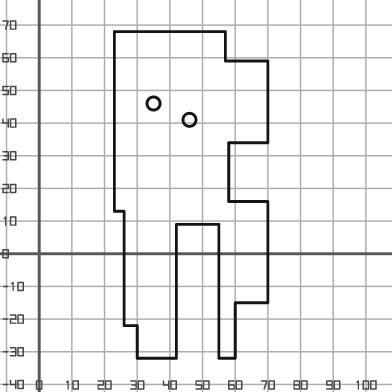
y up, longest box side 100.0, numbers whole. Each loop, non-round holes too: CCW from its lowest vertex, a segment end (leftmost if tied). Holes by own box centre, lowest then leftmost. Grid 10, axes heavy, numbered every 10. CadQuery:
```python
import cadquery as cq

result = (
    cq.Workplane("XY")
    .moveTo(30.0, -32.0)
    .lineTo(42.0, -32.0)
    .lineTo(42.0, 9.0)
    .lineTo(55.0, 9.0)
    .lineTo(55.0, -32.0)
    .lineTo(60.0, -32.0)
    .lineTo(60.0, -15.0)
    .lineTo(70.0, -15.0)
    .lineTo(70.0, 16.0)
    .lineTo(58.0, 16.0)
    .lineTo(58.0, 34.0)
    .lineTo(70.0, 34.0)
    .lineTo(70.0, 59.0)
    .lineTo(57.0, 59.0)
    .lineTo(57.0, 68.0)
    .lineTo(23.0, 68.0)
    .lineTo(23.0, 13.0)
    .lineTo(26.0, 13.0)
    .lineTo(26.0, -22.0)
    .lineTo(30.0, -22.0)
    .close()
    .moveTo(46.0, 41.0)
    .circle(2.0)
    .moveTo(35.0, 46.0)
    .circle(2.0)
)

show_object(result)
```